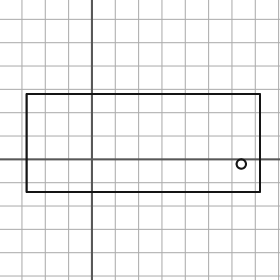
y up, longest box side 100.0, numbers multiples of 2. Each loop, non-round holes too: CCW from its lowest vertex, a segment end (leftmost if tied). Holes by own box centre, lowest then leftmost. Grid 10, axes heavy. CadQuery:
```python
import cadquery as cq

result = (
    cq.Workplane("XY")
    .moveTo(-28.0, -14.0)
    .lineTo(72.0, -14.0)
    .lineTo(72.0, 28.0)
    .lineTo(-28.0, 28.0)
    .close()
    .moveTo(64.0, -2.0)
    .circle(2.0)
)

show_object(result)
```